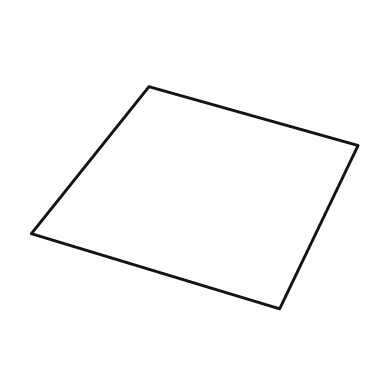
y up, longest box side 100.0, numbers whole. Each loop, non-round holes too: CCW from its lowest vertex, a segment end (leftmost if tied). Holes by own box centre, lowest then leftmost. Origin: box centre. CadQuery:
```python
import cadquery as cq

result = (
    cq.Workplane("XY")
    .moveTo(26.0, -34.0)
    .lineTo(50.0, 16.0)
    .lineTo(-14.0, 34.0)
    .lineTo(-50.0, -11.0)
    .close()
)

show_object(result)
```